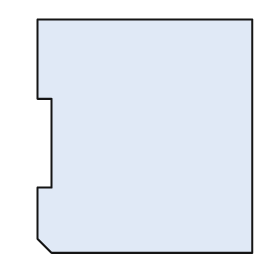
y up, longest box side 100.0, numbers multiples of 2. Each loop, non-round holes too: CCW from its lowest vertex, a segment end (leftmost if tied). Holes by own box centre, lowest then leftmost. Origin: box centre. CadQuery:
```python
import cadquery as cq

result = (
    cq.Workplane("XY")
    .moveTo(-40.0, -50.0)
    .lineTo(46.0, -50.0)
    .lineTo(46.0, 50.0)
    .lineTo(-46.0, 50.0)
    .lineTo(-46.0, 16.0)
    .lineTo(-40.0, 16.0)
    .lineTo(-40.0, -22.0)
    .lineTo(-46.0, -22.0)
    .lineTo(-46.0, -44.0)
    .close()
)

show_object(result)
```